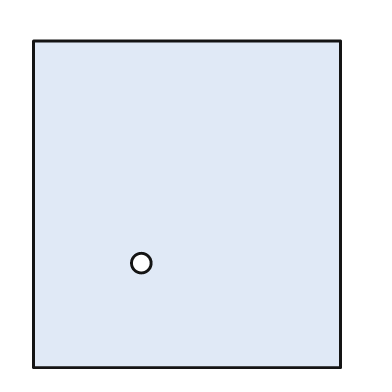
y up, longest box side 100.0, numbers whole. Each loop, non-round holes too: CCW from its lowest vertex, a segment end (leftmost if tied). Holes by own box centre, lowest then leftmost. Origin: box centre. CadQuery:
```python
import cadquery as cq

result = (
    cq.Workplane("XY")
    .moveTo(-47.0, -50.0)
    .lineTo(47.0, -50.0)
    .lineTo(47.0, 50.0)
    .lineTo(-47.0, 50.0)
    .close()
    .moveTo(-14.0, -18.0)
    .circle(3.0)
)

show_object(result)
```